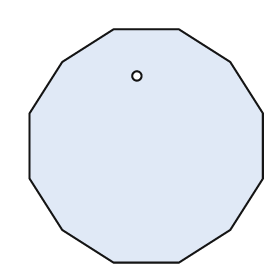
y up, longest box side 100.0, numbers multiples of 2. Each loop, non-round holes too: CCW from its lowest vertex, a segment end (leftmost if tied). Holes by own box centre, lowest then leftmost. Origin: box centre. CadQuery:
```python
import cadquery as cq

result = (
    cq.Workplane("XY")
    .moveTo(-14.0, -50.0)
    .lineTo(14.0, -50.0)
    .lineTo(36.0, -36.0)
    .lineTo(50.0, -14.0)
    .lineTo(50.0, 14.0)
    .lineTo(36.0, 36.0)
    .lineTo(14.0, 50.0)
    .lineTo(-14.0, 50.0)
    .lineTo(-36.0, 36.0)
    .lineTo(-50.0, 14.0)
    .lineTo(-50.0, -14.0)
    .lineTo(-36.0, -36.0)
    .close()
    .moveTo(-4.0, 30.0)
    .circle(2.0)
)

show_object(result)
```